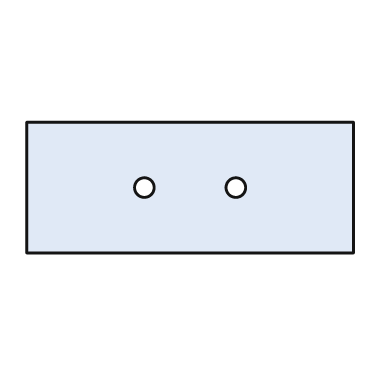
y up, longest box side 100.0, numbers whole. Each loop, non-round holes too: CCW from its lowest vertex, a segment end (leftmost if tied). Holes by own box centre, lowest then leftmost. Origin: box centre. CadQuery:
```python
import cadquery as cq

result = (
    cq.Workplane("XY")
    .moveTo(-50.0, -20.0)
    .lineTo(50.0, -20.0)
    .lineTo(50.0, 20.0)
    .lineTo(-50.0, 20.0)
    .close()
    .moveTo(-14.0, 0.0)
    .circle(3.0)
    .moveTo(14.0, 0.0)
    .circle(3.0)
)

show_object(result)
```